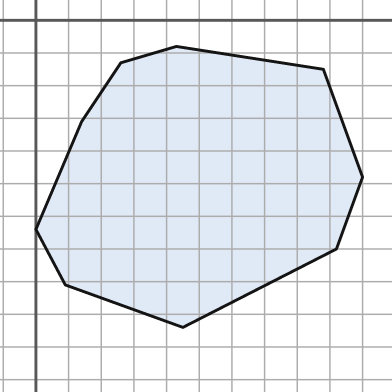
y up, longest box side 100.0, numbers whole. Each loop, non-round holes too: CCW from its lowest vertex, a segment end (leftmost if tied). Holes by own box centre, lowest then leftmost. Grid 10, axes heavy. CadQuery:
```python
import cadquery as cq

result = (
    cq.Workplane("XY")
    .moveTo(45.0, -94.0)
    .lineTo(92.0, -70.0)
    .lineTo(100.0, -48.0)
    .lineTo(88.0, -15.0)
    .lineTo(43.0, -8.0)
    .lineTo(26.0, -13.0)
    .lineTo(14.0, -31.0)
    .lineTo(0.0, -64.0)
    .lineTo(9.0, -81.0)
    .close()
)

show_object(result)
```